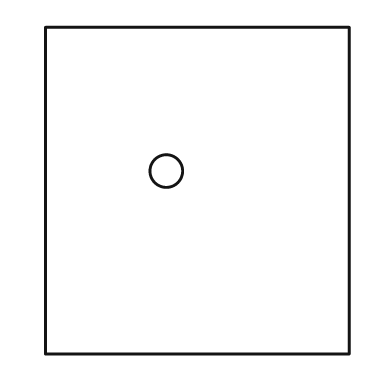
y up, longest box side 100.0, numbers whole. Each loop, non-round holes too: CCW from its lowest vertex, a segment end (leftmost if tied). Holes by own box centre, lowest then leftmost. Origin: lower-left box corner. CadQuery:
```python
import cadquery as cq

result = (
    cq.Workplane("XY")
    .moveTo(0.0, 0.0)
    .lineTo(93.0, 0.0)
    .lineTo(93.0, 100.0)
    .lineTo(0.0, 100.0)
    .close()
    .moveTo(37.0, 56.0)
    .circle(5.0)
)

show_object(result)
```